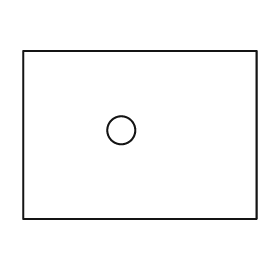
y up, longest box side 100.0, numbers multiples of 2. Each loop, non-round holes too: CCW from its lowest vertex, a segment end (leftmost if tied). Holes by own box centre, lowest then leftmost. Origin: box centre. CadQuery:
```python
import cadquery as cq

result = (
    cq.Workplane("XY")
    .moveTo(-50.0, -36.0)
    .lineTo(50.0, -36.0)
    .lineTo(50.0, 36.0)
    .lineTo(-50.0, 36.0)
    .close()
    .moveTo(-8.0, 2.0)
    .circle(6.0)
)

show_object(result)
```